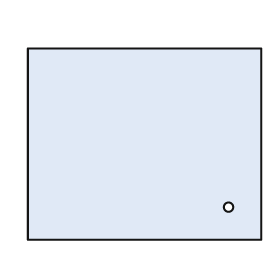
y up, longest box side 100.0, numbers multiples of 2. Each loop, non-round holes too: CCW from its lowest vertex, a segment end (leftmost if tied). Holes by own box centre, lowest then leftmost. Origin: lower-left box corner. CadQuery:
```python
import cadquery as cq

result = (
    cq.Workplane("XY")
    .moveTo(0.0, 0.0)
    .lineTo(100.0, 0.0)
    .lineTo(100.0, 82.0)
    .lineTo(0.0, 82.0)
    .close()
    .moveTo(86.0, 14.0)
    .circle(2.0)
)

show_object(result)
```